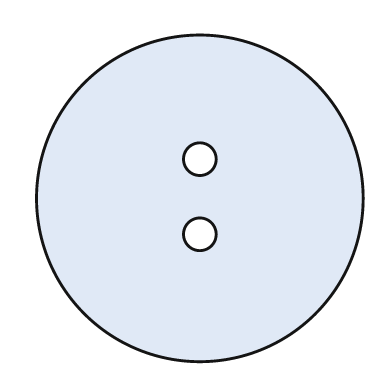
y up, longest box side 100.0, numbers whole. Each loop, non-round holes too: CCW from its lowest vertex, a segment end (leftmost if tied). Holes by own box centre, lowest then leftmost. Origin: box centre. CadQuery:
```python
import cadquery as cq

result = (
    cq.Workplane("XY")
    .moveTo(0.0, 0.0)
    .circle(50.0)
    .moveTo(0.0, -11.0)
    .circle(5.0)
    .moveTo(0.0, 12.0)
    .circle(5.0)
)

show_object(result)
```